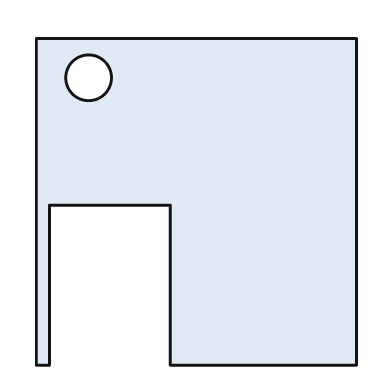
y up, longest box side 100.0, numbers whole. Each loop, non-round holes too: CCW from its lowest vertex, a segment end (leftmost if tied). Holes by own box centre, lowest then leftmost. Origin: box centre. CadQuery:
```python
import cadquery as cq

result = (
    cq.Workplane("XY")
    .moveTo(-49.0, -50.0)
    .lineTo(-45.0, -50.0)
    .lineTo(-45.0, -1.0)
    .lineTo(-8.0, -1.0)
    .lineTo(-8.0, -50.0)
    .lineTo(49.0, -50.0)
    .lineTo(49.0, 50.0)
    .lineTo(-49.0, 50.0)
    .close()
    .moveTo(-33.0, 38.0)
    .circle(7.0)
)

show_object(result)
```